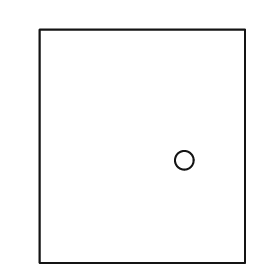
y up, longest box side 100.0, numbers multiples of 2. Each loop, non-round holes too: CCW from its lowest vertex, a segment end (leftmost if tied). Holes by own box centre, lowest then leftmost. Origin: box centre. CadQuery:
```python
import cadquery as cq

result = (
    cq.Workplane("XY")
    .moveTo(-44.0, -50.0)
    .lineTo(44.0, -50.0)
    .lineTo(44.0, 50.0)
    .lineTo(-44.0, 50.0)
    .close()
    .moveTo(18.0, -6.0)
    .circle(4.0)
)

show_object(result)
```